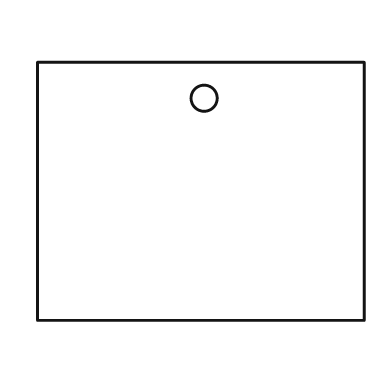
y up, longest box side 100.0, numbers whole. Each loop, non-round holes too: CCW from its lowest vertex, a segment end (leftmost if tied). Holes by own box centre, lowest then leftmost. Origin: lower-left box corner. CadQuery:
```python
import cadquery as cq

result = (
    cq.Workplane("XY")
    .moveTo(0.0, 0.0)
    .lineTo(100.0, 0.0)
    .lineTo(100.0, 79.0)
    .lineTo(0.0, 79.0)
    .close()
    .moveTo(51.0, 68.0)
    .circle(4.0)
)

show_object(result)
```